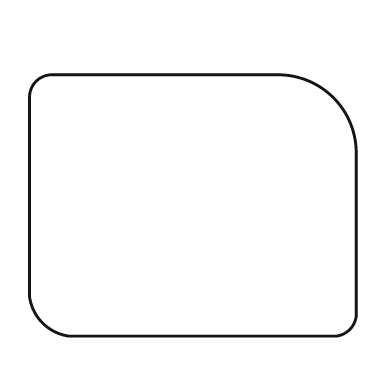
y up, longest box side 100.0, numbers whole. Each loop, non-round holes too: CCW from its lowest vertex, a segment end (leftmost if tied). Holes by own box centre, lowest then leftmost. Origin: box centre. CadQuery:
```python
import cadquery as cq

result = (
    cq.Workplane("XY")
    .moveTo(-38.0, -40.0)
    .lineTo(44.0, -40.0)
    .threePointArc((48.0, -38.0), (50.0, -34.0))
    .lineTo(50.0, 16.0)
    .threePointArc((43.0, 33.0), (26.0, 40.0))
    .lineTo(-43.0, 40.0)
    .threePointArc((-48.0, 38.0), (-50.0, 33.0))
    .lineTo(-50.0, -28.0)
    .threePointArc((-46.0, -36.0), (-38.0, -40.0))
    .close()
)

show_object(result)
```